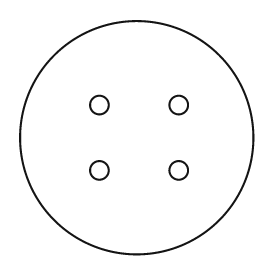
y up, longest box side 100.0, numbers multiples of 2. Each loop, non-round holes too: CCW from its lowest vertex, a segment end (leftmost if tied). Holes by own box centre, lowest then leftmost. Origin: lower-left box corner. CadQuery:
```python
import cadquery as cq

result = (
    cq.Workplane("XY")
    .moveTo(50.0, 50.0)
    .circle(50.0)
    .moveTo(34.0, 36.0)
    .circle(4.0)
    .moveTo(68.0, 36.0)
    .circle(4.0)
    .moveTo(34.0, 64.0)
    .circle(4.0)
    .moveTo(68.0, 64.0)
    .circle(4.0)
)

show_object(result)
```